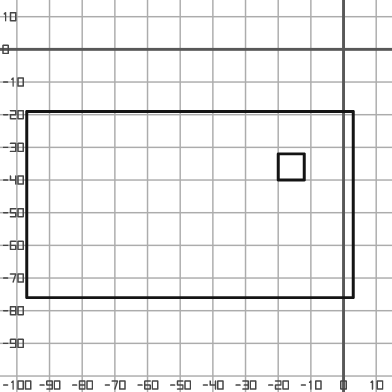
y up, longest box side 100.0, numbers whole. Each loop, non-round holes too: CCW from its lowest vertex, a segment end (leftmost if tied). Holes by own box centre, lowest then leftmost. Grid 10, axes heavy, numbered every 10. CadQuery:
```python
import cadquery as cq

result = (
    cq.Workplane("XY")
    .moveTo(-97.0, -76.0)
    .lineTo(3.0, -76.0)
    .lineTo(3.0, -19.0)
    .lineTo(-97.0, -19.0)
    .close()
    .moveTo(-20.0, -40.0)
    .lineTo(-12.0, -40.0)
    .lineTo(-12.0, -32.0)
    .lineTo(-20.0, -32.0)
    .close()
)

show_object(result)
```